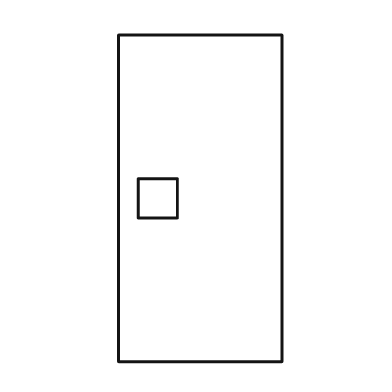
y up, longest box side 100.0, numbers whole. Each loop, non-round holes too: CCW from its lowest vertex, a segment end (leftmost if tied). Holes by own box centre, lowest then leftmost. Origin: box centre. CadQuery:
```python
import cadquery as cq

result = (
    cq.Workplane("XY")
    .moveTo(-25.0, -50.0)
    .lineTo(25.0, -50.0)
    .lineTo(25.0, 50.0)
    .lineTo(-25.0, 50.0)
    .close()
    .moveTo(-19.0, -6.0)
    .lineTo(-7.0, -6.0)
    .lineTo(-7.0, 6.0)
    .lineTo(-19.0, 6.0)
    .close()
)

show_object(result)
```